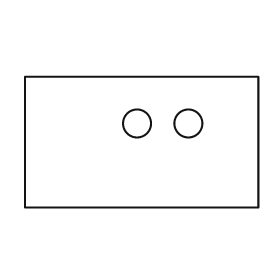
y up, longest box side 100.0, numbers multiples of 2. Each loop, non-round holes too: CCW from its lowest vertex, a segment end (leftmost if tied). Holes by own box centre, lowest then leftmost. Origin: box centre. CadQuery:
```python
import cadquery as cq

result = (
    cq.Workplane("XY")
    .moveTo(-50.0, -28.0)
    .lineTo(50.0, -28.0)
    .lineTo(50.0, 28.0)
    .lineTo(-50.0, 28.0)
    .close()
    .moveTo(-2.0, 8.0)
    .circle(6.0)
    .moveTo(20.0, 8.0)
    .circle(6.0)
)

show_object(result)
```